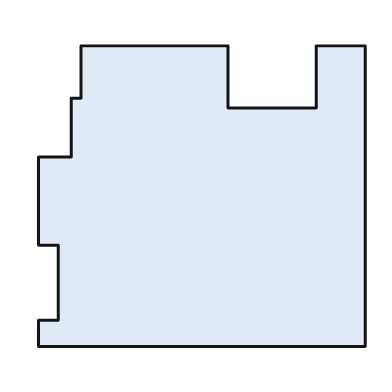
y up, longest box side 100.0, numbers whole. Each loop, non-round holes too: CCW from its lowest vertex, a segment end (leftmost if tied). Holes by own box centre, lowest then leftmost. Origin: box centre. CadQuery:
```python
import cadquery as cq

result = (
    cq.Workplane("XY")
    .moveTo(-50.0, -46.0)
    .lineTo(50.0, -46.0)
    .lineTo(50.0, 46.0)
    .lineTo(35.0, 46.0)
    .lineTo(35.0, 27.0)
    .lineTo(8.0, 27.0)
    .lineTo(8.0, 46.0)
    .lineTo(-37.0, 46.0)
    .lineTo(-37.0, 30.0)
    .lineTo(-40.0, 30.0)
    .lineTo(-40.0, 12.0)
    .lineTo(-50.0, 12.0)
    .lineTo(-50.0, -15.0)
    .lineTo(-44.0, -15.0)
    .lineTo(-44.0, -38.0)
    .lineTo(-50.0, -38.0)
    .close()
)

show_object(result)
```